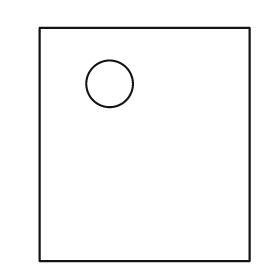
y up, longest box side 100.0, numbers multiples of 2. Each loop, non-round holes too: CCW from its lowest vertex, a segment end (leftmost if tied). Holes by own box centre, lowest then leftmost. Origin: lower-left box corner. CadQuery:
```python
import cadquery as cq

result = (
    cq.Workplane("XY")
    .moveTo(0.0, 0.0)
    .lineTo(90.0, 0.0)
    .lineTo(90.0, 100.0)
    .lineTo(0.0, 100.0)
    .close()
    .moveTo(30.0, 76.0)
    .circle(10.0)
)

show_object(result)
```